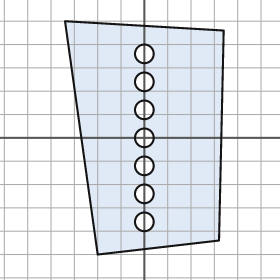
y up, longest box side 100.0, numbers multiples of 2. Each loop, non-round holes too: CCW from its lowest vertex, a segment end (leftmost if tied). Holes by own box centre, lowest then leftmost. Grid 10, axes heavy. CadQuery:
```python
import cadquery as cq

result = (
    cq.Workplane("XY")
    .moveTo(-20.0, -50.0)
    .lineTo(32.0, -44.0)
    .lineTo(34.0, 46.0)
    .lineTo(-34.0, 50.0)
    .close()
    .moveTo(0.0, -36.0)
    .circle(4.0)
    .moveTo(0.0, -24.0)
    .circle(4.0)
    .moveTo(0.0, -12.0)
    .circle(4.0)
    .moveTo(0.0, 0.0)
    .circle(4.0)
    .moveTo(0.0, 12.0)
    .circle(4.0)
    .moveTo(0.0, 24.0)
    .circle(4.0)
    .moveTo(0.0, 36.0)
    .circle(4.0)
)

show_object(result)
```